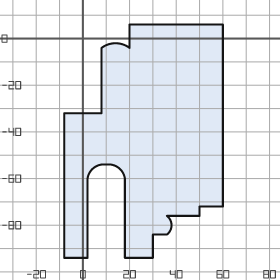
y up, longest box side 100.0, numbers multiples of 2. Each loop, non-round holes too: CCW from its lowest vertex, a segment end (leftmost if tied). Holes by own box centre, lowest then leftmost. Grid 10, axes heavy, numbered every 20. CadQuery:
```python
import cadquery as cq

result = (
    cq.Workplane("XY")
    .moveTo(-8.0, -94.0)
    .lineTo(2.0, -94.0)
    .lineTo(2.0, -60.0)
    .threePointArc((4.0, -56.0), (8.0, -54.0))
    .lineTo(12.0, -54.0)
    .threePointArc((16.0, -56.0), (18.0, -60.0))
    .lineTo(18.0, -94.0)
    .lineTo(30.0, -94.0)
    .lineTo(30.0, -84.0)
    .lineTo(36.0, -84.0)
    .threePointArc((38.0, -80.0), (36.0, -76.0))
    .lineTo(50.0, -76.0)
    .lineTo(50.0, -72.0)
    .lineTo(60.0, -72.0)
    .lineTo(60.0, 6.0)
    .lineTo(20.0, 6.0)
    .lineTo(20.0, -4.0)
    .threePointArc((14.0, -2.0), (8.0, -4.0))
    .lineTo(8.0, -32.0)
    .lineTo(-8.0, -32.0)
    .close()
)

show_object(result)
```